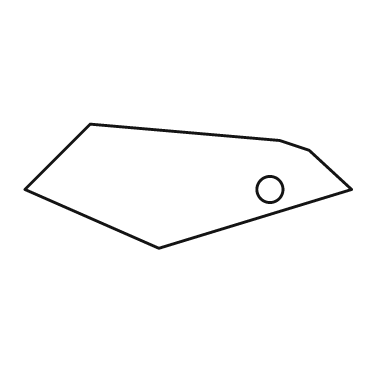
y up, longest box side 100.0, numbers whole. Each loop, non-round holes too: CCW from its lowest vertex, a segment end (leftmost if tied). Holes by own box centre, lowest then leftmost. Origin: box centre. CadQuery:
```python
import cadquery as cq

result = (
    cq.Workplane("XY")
    .moveTo(-9.0, -19.0)
    .lineTo(50.0, -1.0)
    .lineTo(37.0, 11.0)
    .lineTo(28.0, 14.0)
    .lineTo(-30.0, 19.0)
    .lineTo(-50.0, -1.0)
    .close()
    .moveTo(25.0, -1.0)
    .circle(4.0)
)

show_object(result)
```